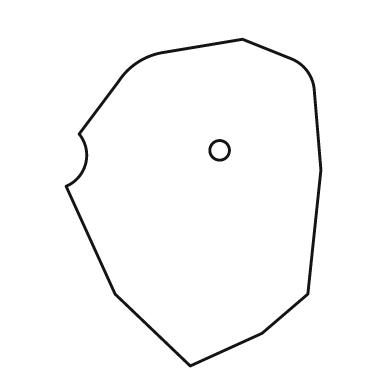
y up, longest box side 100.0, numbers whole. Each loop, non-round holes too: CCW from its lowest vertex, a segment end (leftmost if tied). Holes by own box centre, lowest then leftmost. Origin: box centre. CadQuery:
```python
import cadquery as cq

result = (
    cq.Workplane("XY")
    .moveTo(-1.0, -50.0)
    .lineTo(21.0, -40.0)
    .lineTo(35.0, -28.0)
    .lineTo(39.0, 10.0)
    .lineTo(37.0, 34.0)
    .threePointArc((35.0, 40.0), (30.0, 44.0))
    .lineTo(15.0, 50.0)
    .lineTo(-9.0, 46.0)
    .threePointArc((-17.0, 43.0), (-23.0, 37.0))
    .lineTo(-35.0, 21.0)
    .threePointArc((-33.0, 12.0), (-39.0, 5.0))
    .lineTo(-24.0, -28.0)
    .close()
    .moveTo(8.0, 16.0)
    .circle(3.0)
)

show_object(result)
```